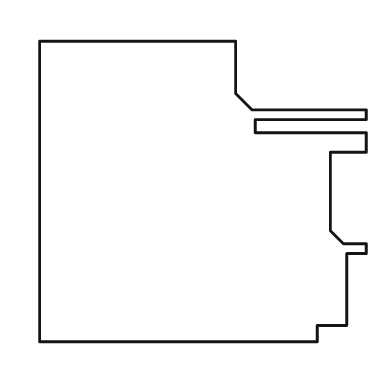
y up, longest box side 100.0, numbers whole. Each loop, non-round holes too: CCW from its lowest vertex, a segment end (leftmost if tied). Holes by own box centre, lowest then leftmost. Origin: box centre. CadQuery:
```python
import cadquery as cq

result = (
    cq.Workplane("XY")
    .moveTo(-50.0, -46.0)
    .lineTo(35.0, -46.0)
    .lineTo(35.0, -41.0)
    .lineTo(44.0, -41.0)
    .lineTo(44.0, -19.0)
    .lineTo(50.0, -19.0)
    .lineTo(50.0, -16.0)
    .lineTo(43.0, -16.0)
    .lineTo(39.0, -12.0)
    .lineTo(39.0, 12.0)
    .lineTo(50.0, 12.0)
    .lineTo(50.0, 18.0)
    .lineTo(16.0, 18.0)
    .lineTo(16.0, 22.0)
    .lineTo(50.0, 22.0)
    .lineTo(50.0, 25.0)
    .lineTo(15.0, 25.0)
    .lineTo(10.0, 30.0)
    .lineTo(10.0, 46.0)
    .lineTo(-50.0, 46.0)
    .close()
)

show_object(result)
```